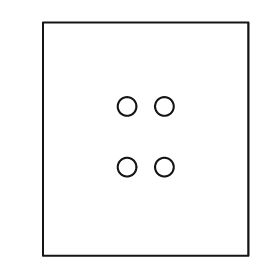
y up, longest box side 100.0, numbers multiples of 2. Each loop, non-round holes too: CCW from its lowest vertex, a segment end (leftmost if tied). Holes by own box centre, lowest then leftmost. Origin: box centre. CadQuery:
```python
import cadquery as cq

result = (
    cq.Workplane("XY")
    .moveTo(-44.0, -50.0)
    .lineTo(44.0, -50.0)
    .lineTo(44.0, 50.0)
    .lineTo(-44.0, 50.0)
    .close()
    .moveTo(-8.0, -12.0)
    .circle(4.0)
    .moveTo(8.0, -12.0)
    .circle(4.0)
    .moveTo(-8.0, 14.0)
    .circle(4.0)
    .moveTo(8.0, 14.0)
    .circle(4.0)
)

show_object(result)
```